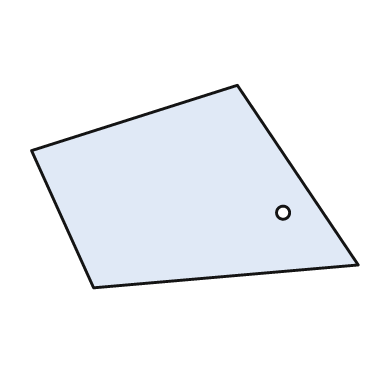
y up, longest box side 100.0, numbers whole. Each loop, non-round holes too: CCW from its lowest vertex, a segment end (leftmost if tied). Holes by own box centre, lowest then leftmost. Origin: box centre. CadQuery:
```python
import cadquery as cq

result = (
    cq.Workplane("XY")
    .moveTo(-31.0, -31.0)
    .lineTo(50.0, -24.0)
    .lineTo(13.0, 31.0)
    .lineTo(-50.0, 11.0)
    .close()
    .moveTo(27.0, -8.0)
    .circle(2.0)
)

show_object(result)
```